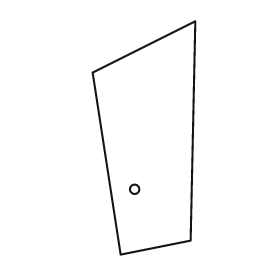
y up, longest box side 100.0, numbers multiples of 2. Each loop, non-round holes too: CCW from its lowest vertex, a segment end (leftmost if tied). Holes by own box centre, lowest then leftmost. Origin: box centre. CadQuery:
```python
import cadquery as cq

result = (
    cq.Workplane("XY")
    .moveTo(-10.0, -50.0)
    .lineTo(20.0, -44.0)
    .lineTo(22.0, 50.0)
    .lineTo(-22.0, 28.0)
    .close()
    .moveTo(-4.0, -22.0)
    .circle(2.0)
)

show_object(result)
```